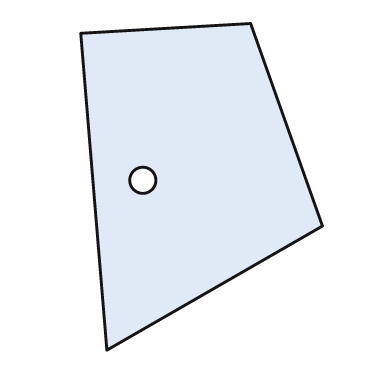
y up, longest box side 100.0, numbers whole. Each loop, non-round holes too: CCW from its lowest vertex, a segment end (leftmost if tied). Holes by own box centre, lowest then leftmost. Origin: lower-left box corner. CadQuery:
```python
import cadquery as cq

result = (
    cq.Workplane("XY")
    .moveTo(8.0, 0.0)
    .lineTo(74.0, 38.0)
    .lineTo(52.0, 100.0)
    .lineTo(0.0, 97.0)
    .close()
    .moveTo(19.0, 52.0)
    .circle(4.0)
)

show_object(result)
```